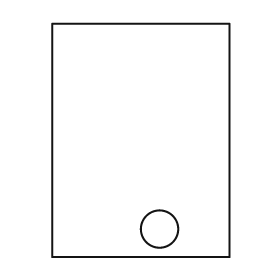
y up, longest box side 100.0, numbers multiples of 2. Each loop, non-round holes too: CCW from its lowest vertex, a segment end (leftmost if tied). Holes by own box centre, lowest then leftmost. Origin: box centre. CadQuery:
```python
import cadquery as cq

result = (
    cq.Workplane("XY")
    .moveTo(-38.0, -50.0)
    .lineTo(38.0, -50.0)
    .lineTo(38.0, 50.0)
    .lineTo(-38.0, 50.0)
    .close()
    .moveTo(8.0, -38.0)
    .circle(8.0)
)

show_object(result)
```